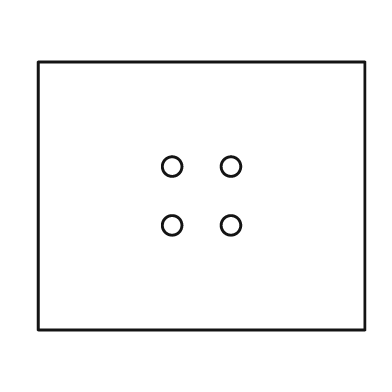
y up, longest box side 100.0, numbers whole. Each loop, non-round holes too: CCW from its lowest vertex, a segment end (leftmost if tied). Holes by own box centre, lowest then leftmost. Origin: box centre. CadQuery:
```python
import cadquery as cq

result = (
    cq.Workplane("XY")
    .moveTo(-50.0, -41.0)
    .lineTo(50.0, -41.0)
    .lineTo(50.0, 41.0)
    .lineTo(-50.0, 41.0)
    .close()
    .moveTo(-9.0, -9.0)
    .circle(3.0)
    .moveTo(9.0, -9.0)
    .circle(3.0)
    .moveTo(-9.0, 9.0)
    .circle(3.0)
    .moveTo(9.0, 9.0)
    .circle(3.0)
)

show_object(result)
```